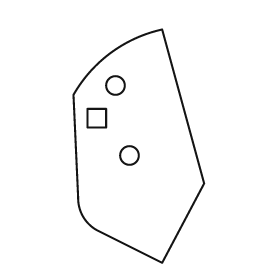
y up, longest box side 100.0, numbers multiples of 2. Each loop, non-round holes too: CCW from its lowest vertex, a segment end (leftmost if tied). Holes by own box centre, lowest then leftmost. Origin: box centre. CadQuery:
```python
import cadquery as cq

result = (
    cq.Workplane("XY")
    .moveTo(10.0, -50.0)
    .lineTo(28.0, -16.0)
    .lineTo(10.0, 50.0)
    .threePointArc((-12.0, 40.0), (-28.0, 22.0))
    .lineTo(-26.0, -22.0)
    .threePointArc((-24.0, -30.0), (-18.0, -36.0))
    .close()
    .moveTo(-4.0, -4.0)
    .circle(4.0)
    .moveTo(-22.0, 8.0)
    .lineTo(-14.0, 8.0)
    .lineTo(-14.0, 16.0)
    .lineTo(-22.0, 16.0)
    .close()
    .moveTo(-10.0, 26.0)
    .circle(4.0)
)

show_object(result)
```